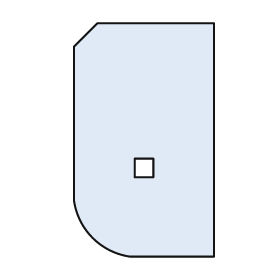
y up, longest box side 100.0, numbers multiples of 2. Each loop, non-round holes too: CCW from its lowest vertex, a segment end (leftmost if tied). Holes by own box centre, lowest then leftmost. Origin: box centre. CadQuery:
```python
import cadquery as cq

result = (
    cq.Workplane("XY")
    .moveTo(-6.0, -50.0)
    .lineTo(30.0, -50.0)
    .lineTo(30.0, 50.0)
    .lineTo(-20.0, 50.0)
    .lineTo(-30.0, 40.0)
    .lineTo(-30.0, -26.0)
    .threePointArc((-22.0, -42.0), (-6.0, -50.0))
    .close()
    .moveTo(-4.0, -16.0)
    .lineTo(4.0, -16.0)
    .lineTo(4.0, -8.0)
    .lineTo(-4.0, -8.0)
    .close()
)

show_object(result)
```